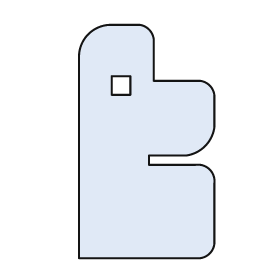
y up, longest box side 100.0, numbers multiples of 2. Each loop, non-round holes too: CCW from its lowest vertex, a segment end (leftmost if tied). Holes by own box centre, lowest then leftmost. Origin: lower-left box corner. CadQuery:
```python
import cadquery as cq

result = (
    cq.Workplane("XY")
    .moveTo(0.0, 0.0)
    .lineTo(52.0, 0.0)
    .threePointArc((56.0, 2.0), (58.0, 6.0))
    .lineTo(58.0, 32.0)
    .threePointArc((56.0, 38.0), (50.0, 40.0))
    .lineTo(30.0, 40.0)
    .lineTo(30.0, 44.0)
    .lineTo(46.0, 44.0)
    .threePointArc((54.0, 48.0), (58.0, 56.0))
    .lineTo(58.0, 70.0)
    .threePointArc((56.0, 74.0), (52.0, 76.0))
    .lineTo(32.0, 76.0)
    .lineTo(32.0, 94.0)
    .threePointArc((30.0, 98.0), (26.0, 100.0))
    .lineTo(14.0, 100.0)
    .threePointArc((4.0, 96.0), (0.0, 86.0))
    .close()
    .moveTo(14.0, 70.0)
    .lineTo(22.0, 70.0)
    .lineTo(22.0, 78.0)
    .lineTo(14.0, 78.0)
    .close()
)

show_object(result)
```